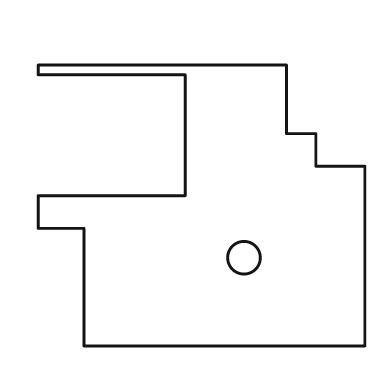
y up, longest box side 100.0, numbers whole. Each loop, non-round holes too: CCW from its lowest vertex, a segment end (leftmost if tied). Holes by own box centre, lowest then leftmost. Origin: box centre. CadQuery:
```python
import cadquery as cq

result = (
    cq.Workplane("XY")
    .moveTo(-36.0, -43.0)
    .lineTo(50.0, -43.0)
    .lineTo(50.0, 12.0)
    .lineTo(35.0, 12.0)
    .lineTo(35.0, 22.0)
    .lineTo(26.0, 22.0)
    .lineTo(26.0, 43.0)
    .lineTo(-50.0, 43.0)
    .lineTo(-50.0, 40.0)
    .lineTo(-5.0, 40.0)
    .lineTo(-5.0, 3.0)
    .lineTo(-50.0, 3.0)
    .lineTo(-50.0, -7.0)
    .lineTo(-36.0, -7.0)
    .close()
    .moveTo(13.0, -16.0)
    .circle(5.0)
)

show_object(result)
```